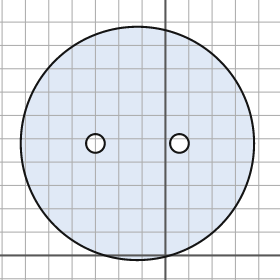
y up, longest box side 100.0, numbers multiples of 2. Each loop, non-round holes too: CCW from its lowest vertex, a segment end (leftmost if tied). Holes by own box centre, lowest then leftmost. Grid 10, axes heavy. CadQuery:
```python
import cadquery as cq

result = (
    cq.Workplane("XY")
    .moveTo(-12.0, 48.0)
    .circle(50.0)
    .moveTo(-30.0, 48.0)
    .circle(4.0)
    .moveTo(6.0, 48.0)
    .circle(4.0)
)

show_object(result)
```